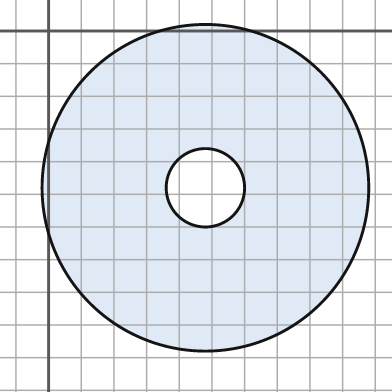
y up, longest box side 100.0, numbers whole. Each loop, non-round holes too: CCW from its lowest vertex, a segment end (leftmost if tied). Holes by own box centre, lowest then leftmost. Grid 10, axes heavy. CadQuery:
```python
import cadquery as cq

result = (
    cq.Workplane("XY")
    .moveTo(48.0, -48.0)
    .circle(50.0)
    .moveTo(48.0, -48.0)
    .circle(12.0)
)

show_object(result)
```